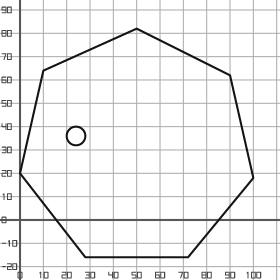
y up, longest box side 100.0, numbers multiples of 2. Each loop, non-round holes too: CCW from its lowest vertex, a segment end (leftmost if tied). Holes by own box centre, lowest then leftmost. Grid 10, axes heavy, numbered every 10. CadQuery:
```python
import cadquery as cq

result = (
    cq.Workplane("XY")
    .moveTo(28.0, -16.0)
    .lineTo(72.0, -16.0)
    .lineTo(100.0, 18.0)
    .lineTo(90.0, 62.0)
    .lineTo(50.0, 82.0)
    .lineTo(10.0, 64.0)
    .lineTo(0.0, 20.0)
    .close()
    .moveTo(24.0, 36.0)
    .circle(4.0)
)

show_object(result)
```